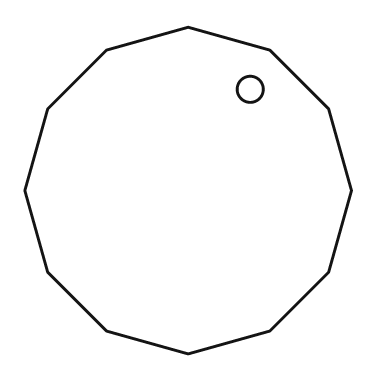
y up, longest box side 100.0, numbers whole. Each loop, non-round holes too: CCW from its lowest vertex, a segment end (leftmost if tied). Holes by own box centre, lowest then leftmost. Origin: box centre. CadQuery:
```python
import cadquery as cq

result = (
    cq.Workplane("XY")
    .moveTo(0.0, -50.0)
    .lineTo(25.0, -43.0)
    .lineTo(43.0, -25.0)
    .lineTo(50.0, 0.0)
    .lineTo(43.0, 25.0)
    .lineTo(25.0, 43.0)
    .lineTo(0.0, 50.0)
    .lineTo(-25.0, 43.0)
    .lineTo(-43.0, 25.0)
    .lineTo(-50.0, 0.0)
    .lineTo(-43.0, -25.0)
    .lineTo(-25.0, -43.0)
    .close()
    .moveTo(19.0, 31.0)
    .circle(4.0)
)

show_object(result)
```